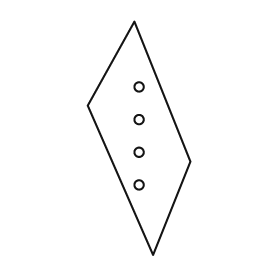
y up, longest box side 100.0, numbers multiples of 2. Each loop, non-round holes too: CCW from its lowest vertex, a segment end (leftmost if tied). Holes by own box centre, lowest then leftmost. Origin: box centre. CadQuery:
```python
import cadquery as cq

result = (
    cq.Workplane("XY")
    .moveTo(6.0, -50.0)
    .lineTo(22.0, -10.0)
    .lineTo(-2.0, 50.0)
    .lineTo(-22.0, 14.0)
    .close()
    .moveTo(0.0, -20.0)
    .circle(2.0)
    .moveTo(0.0, -6.0)
    .circle(2.0)
    .moveTo(0.0, 8.0)
    .circle(2.0)
    .moveTo(0.0, 22.0)
    .circle(2.0)
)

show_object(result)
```